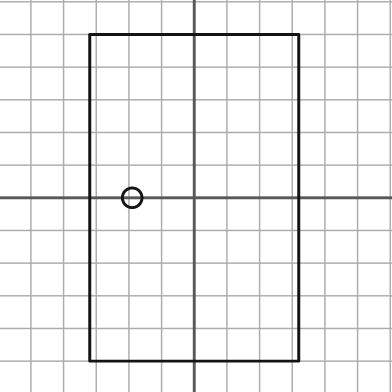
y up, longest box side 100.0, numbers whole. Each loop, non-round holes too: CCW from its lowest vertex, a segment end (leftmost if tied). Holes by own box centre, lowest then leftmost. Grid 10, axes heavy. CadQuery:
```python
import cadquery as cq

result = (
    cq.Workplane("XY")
    .moveTo(-32.0, -50.0)
    .lineTo(32.0, -50.0)
    .lineTo(32.0, 50.0)
    .lineTo(-32.0, 50.0)
    .close()
    .moveTo(-19.0, 0.0)
    .circle(3.0)
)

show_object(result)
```